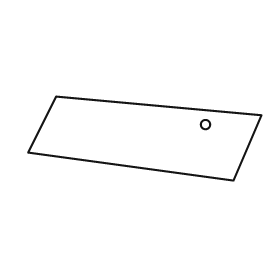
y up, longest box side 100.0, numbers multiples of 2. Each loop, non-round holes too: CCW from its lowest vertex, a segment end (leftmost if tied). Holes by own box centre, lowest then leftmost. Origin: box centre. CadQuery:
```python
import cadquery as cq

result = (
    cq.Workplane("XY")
    .moveTo(38.0, -18.0)
    .lineTo(50.0, 10.0)
    .lineTo(-38.0, 18.0)
    .lineTo(-50.0, -6.0)
    .close()
    .moveTo(26.0, 6.0)
    .circle(2.0)
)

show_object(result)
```